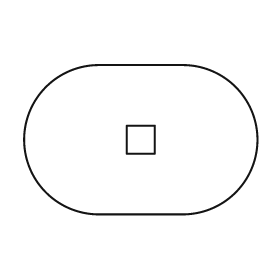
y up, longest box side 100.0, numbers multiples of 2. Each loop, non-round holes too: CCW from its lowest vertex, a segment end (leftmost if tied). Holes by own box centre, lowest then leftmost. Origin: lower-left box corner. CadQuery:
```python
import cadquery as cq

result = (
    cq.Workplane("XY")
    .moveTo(32.0, 0.0)
    .lineTo(68.0, 0.0)
    .threePointArc((100.0, 32.0), (68.0, 64.0))
    .lineTo(32.0, 64.0)
    .threePointArc((0.0, 32.0), (32.0, 0.0))
    .close()
    .moveTo(44.0, 26.0)
    .lineTo(56.0, 26.0)
    .lineTo(56.0, 38.0)
    .lineTo(44.0, 38.0)
    .close()
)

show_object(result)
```